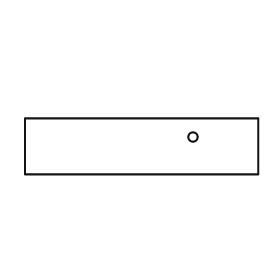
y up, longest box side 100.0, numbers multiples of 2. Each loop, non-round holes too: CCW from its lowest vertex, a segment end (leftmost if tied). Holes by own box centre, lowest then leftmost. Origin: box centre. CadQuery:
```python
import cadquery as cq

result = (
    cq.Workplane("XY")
    .moveTo(-50.0, -12.0)
    .lineTo(50.0, -12.0)
    .lineTo(50.0, 12.0)
    .lineTo(-50.0, 12.0)
    .close()
    .moveTo(22.0, 4.0)
    .circle(2.0)
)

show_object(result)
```